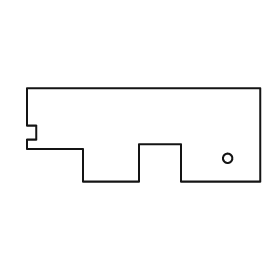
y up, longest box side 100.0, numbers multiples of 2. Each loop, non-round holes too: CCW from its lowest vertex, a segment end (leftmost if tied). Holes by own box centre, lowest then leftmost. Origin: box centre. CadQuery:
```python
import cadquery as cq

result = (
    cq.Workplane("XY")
    .moveTo(-26.0, -20.0)
    .lineTo(-2.0, -20.0)
    .lineTo(-2.0, -4.0)
    .lineTo(16.0, -4.0)
    .lineTo(16.0, -20.0)
    .lineTo(50.0, -20.0)
    .lineTo(50.0, 20.0)
    .lineTo(-50.0, 20.0)
    .lineTo(-50.0, 4.0)
    .lineTo(-46.0, 4.0)
    .lineTo(-46.0, -2.0)
    .lineTo(-50.0, -2.0)
    .lineTo(-50.0, -6.0)
    .lineTo(-26.0, -6.0)
    .close()
    .moveTo(36.0, -10.0)
    .circle(2.0)
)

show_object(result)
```